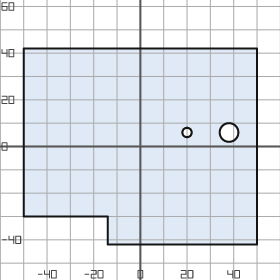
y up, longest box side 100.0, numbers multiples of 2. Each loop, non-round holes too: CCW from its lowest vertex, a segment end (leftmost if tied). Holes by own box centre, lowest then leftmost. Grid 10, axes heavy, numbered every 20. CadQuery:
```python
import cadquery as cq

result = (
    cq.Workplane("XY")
    .moveTo(-14.0, -42.0)
    .lineTo(50.0, -42.0)
    .lineTo(50.0, 42.0)
    .lineTo(-50.0, 42.0)
    .lineTo(-50.0, -30.0)
    .lineTo(-14.0, -30.0)
    .close()
    .moveTo(20.0, 6.0)
    .circle(2.0)
    .moveTo(38.0, 6.0)
    .circle(4.0)
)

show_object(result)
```